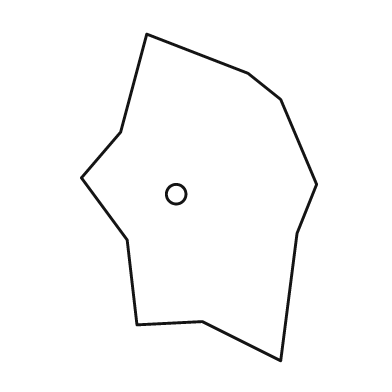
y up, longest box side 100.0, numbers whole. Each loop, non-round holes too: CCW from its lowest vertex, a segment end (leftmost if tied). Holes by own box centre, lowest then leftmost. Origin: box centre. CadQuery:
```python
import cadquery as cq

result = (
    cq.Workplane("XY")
    .moveTo(25.0, -50.0)
    .lineTo(30.0, -11.0)
    .lineTo(36.0, 4.0)
    .lineTo(25.0, 30.0)
    .lineTo(15.0, 38.0)
    .lineTo(-16.0, 50.0)
    .lineTo(-24.0, 20.0)
    .lineTo(-36.0, 6.0)
    .lineTo(-22.0, -13.0)
    .lineTo(-19.0, -39.0)
    .lineTo(1.0, -38.0)
    .close()
    .moveTo(-7.0, 1.0)
    .circle(3.0)
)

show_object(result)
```